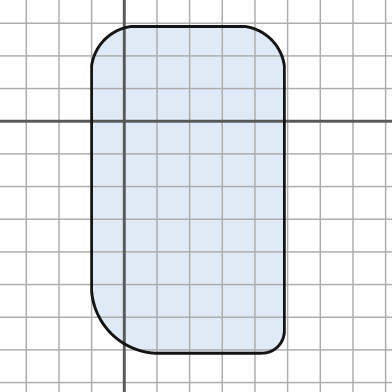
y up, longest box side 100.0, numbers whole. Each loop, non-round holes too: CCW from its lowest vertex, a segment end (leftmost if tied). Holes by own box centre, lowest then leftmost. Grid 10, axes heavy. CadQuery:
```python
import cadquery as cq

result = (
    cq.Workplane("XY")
    .moveTo(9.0, -71.0)
    .lineTo(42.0, -71.0)
    .threePointArc((47.0, -69.0), (49.0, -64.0))
    .lineTo(49.0, 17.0)
    .threePointArc((45.0, 25.0), (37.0, 29.0))
    .lineTo(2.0, 29.0)
    .threePointArc((-6.0, 25.0), (-10.0, 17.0))
    .lineTo(-10.0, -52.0)
    .threePointArc((-4.0, -65.0), (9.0, -71.0))
    .close()
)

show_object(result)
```